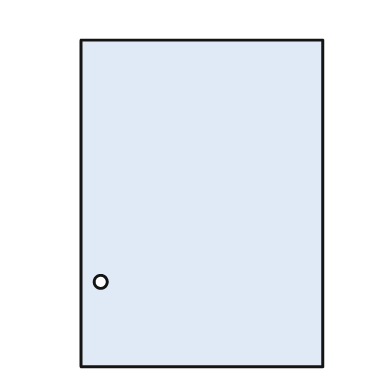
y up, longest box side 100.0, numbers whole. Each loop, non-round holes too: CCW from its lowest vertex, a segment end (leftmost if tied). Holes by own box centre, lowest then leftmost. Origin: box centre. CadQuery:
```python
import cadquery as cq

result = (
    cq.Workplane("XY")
    .moveTo(-37.0, -50.0)
    .lineTo(37.0, -50.0)
    .lineTo(37.0, 50.0)
    .lineTo(-37.0, 50.0)
    .close()
    .moveTo(-31.0, -24.0)
    .circle(2.0)
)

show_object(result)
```